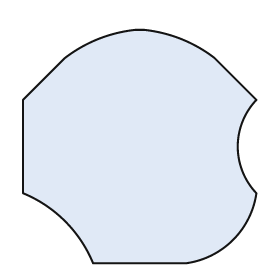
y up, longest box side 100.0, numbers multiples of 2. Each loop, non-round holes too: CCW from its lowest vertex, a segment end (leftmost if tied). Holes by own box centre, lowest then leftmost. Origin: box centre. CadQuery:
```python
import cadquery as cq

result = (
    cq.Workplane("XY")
    .moveTo(-20.0, -50.0)
    .lineTo(20.0, -50.0)
    .threePointArc((40.0, -40.0), (50.0, -20.0))
    .threePointArc((42.0, 0.0), (50.0, 20.0))
    .lineTo(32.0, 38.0)
    .threePointArc((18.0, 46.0), (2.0, 50.0))
    .lineTo(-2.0, 50.0)
    .threePointArc((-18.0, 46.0), (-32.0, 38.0))
    .lineTo(-50.0, 20.0)
    .lineTo(-50.0, -20.0)
    .threePointArc((-32.0, -32.0), (-20.0, -50.0))
    .close()
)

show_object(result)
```